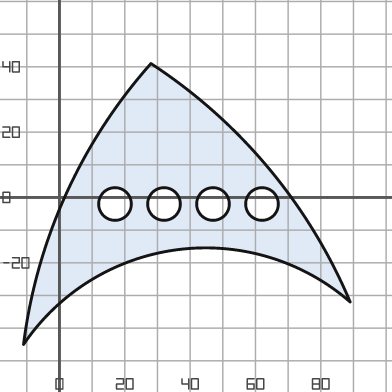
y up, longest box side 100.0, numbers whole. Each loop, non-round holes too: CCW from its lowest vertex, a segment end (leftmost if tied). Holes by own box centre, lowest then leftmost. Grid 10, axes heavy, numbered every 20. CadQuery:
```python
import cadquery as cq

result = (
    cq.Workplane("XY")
    .moveTo(-11.0, -45.0)
    .threePointArc((36.0, -16.0), (89.0, -32.0))
    .threePointArc((64.0, 9.0), (28.0, 41.0))
    .threePointArc((2.0, 1.0), (-11.0, -45.0))
    .close()
    .moveTo(17.0, -2.0)
    .circle(5.0)
    .moveTo(32.0, -2.0)
    .circle(5.0)
    .moveTo(47.0, -2.0)
    .circle(5.0)
    .moveTo(62.0, -2.0)
    .circle(5.0)
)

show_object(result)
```